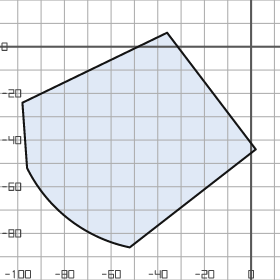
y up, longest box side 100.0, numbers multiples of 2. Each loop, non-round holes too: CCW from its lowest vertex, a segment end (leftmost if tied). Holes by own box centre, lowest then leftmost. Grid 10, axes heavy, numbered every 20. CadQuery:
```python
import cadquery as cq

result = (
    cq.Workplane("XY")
    .moveTo(-52.0, -86.0)
    .lineTo(2.0, -44.0)
    .lineTo(-36.0, 6.0)
    .lineTo(-98.0, -24.0)
    .lineTo(-96.0, -52.0)
    .threePointArc((-78.0, -74.0), (-52.0, -86.0))
    .close()
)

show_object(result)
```